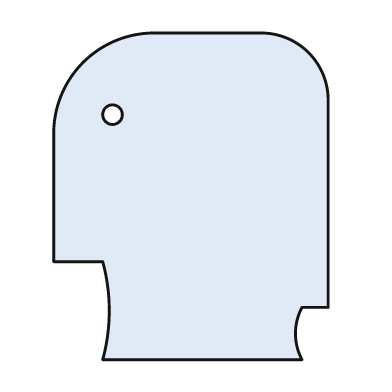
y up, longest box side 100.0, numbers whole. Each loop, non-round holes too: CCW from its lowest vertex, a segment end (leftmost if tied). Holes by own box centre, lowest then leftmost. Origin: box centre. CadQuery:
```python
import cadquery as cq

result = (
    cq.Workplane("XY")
    .moveTo(-27.0, -50.0)
    .lineTo(34.0, -50.0)
    .threePointArc((32.0, -42.0), (34.0, -34.0))
    .lineTo(42.0, -34.0)
    .lineTo(42.0, 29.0)
    .threePointArc((36.0, 44.0), (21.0, 50.0))
    .lineTo(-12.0, 50.0)
    .threePointArc((-33.0, 41.0), (-42.0, 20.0))
    .lineTo(-42.0, -20.0)
    .lineTo(-27.0, -20.0)
    .threePointArc((-25.0, -35.0), (-27.0, -50.0))
    .close()
    .moveTo(-24.0, 25.0)
    .circle(3.0)
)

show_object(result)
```